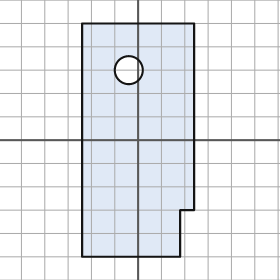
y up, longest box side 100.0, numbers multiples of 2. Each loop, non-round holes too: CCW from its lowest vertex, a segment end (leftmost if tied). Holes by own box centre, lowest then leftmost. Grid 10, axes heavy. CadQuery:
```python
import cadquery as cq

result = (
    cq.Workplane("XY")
    .moveTo(-24.0, -50.0)
    .lineTo(18.0, -50.0)
    .lineTo(18.0, -30.0)
    .lineTo(24.0, -30.0)
    .lineTo(24.0, 50.0)
    .lineTo(-24.0, 50.0)
    .close()
    .moveTo(-4.0, 30.0)
    .circle(6.0)
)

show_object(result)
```